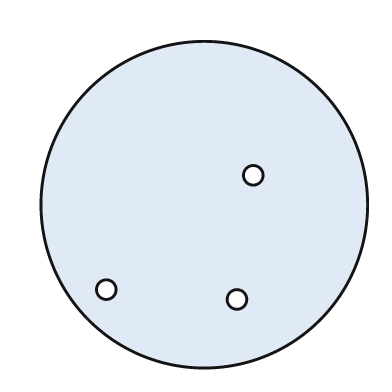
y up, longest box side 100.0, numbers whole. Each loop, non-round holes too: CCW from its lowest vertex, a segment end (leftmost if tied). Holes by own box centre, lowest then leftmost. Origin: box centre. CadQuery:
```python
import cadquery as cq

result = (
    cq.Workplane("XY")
    .moveTo(0.0, 0.0)
    .circle(50.0)
    .moveTo(10.0, -29.0)
    .circle(3.0)
    .moveTo(-30.0, -26.0)
    .circle(3.0)
    .moveTo(15.0, 9.0)
    .circle(3.0)
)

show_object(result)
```